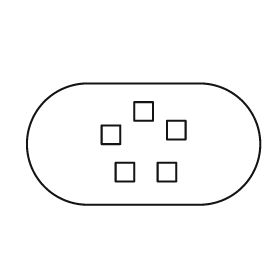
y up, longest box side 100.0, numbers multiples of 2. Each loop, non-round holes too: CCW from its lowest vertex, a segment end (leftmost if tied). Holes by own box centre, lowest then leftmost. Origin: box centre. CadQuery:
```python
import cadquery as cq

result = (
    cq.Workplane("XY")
    .moveTo(-24.0, -26.0)
    .lineTo(24.0, -26.0)
    .threePointArc((50.0, 0.0), (24.0, 26.0))
    .lineTo(-24.0, 26.0)
    .threePointArc((-50.0, 0.0), (-24.0, -26.0))
    .close()
    .moveTo(-12.0, -16.0)
    .lineTo(-4.0, -16.0)
    .lineTo(-4.0, -8.0)
    .lineTo(-12.0, -8.0)
    .close()
    .moveTo(6.0, -16.0)
    .lineTo(14.0, -16.0)
    .lineTo(14.0, -8.0)
    .lineTo(6.0, -8.0)
    .close()
    .moveTo(-18.0, 0.0)
    .lineTo(-10.0, 0.0)
    .lineTo(-10.0, 8.0)
    .lineTo(-18.0, 8.0)
    .close()
    .moveTo(10.0, 2.0)
    .lineTo(18.0, 2.0)
    .lineTo(18.0, 10.0)
    .lineTo(10.0, 10.0)
    .close()
    .moveTo(-4.0, 10.0)
    .lineTo(4.0, 10.0)
    .lineTo(4.0, 18.0)
    .lineTo(-4.0, 18.0)
    .close()
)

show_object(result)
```